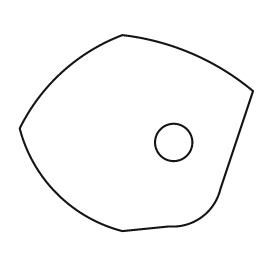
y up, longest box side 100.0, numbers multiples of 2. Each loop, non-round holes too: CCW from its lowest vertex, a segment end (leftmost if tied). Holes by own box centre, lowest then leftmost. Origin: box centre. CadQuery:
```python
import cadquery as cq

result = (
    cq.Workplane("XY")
    .moveTo(-6.0, -42.0)
    .lineTo(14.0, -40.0)
    .threePointArc((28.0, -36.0), (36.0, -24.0))
    .lineTo(50.0, 18.0)
    .threePointArc((24.0, 34.0), (-6.0, 42.0))
    .threePointArc((-32.0, 26.0), (-50.0, 2.0))
    .threePointArc((-34.0, -26.0), (-6.0, -42.0))
    .close()
    .moveTo(16.0, -4.0)
    .circle(8.0)
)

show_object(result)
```